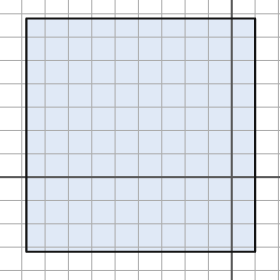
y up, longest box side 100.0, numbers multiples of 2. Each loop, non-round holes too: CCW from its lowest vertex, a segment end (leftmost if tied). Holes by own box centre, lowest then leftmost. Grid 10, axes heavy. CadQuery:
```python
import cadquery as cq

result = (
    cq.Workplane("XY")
    .moveTo(-88.0, -32.0)
    .lineTo(10.0, -32.0)
    .lineTo(10.0, 68.0)
    .lineTo(-88.0, 68.0)
    .close()
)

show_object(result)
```